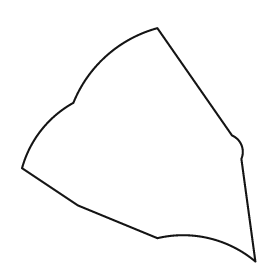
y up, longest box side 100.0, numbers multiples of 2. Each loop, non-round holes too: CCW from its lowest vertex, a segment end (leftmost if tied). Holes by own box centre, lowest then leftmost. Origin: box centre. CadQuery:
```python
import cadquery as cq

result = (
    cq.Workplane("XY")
    .moveTo(50.0, -50.0)
    .lineTo(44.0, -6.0)
    .threePointArc((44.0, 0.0), (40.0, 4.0))
    .lineTo(8.0, 50.0)
    .threePointArc((-14.0, 38.0), (-28.0, 18.0))
    .threePointArc((-42.0, 6.0), (-50.0, -10.0))
    .lineTo(-26.0, -26.0)
    .lineTo(8.0, -40.0)
    .threePointArc((30.0, -40.0), (50.0, -50.0))
    .close()
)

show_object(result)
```